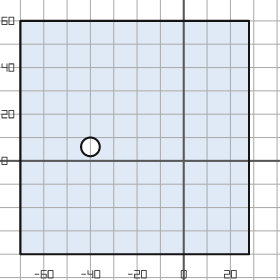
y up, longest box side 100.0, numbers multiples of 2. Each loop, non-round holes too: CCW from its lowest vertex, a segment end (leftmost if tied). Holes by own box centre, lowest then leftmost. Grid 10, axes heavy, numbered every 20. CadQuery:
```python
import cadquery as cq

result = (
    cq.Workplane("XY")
    .moveTo(-70.0, -40.0)
    .lineTo(28.0, -40.0)
    .lineTo(28.0, 60.0)
    .lineTo(-70.0, 60.0)
    .close()
    .moveTo(-40.0, 6.0)
    .circle(4.0)
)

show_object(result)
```